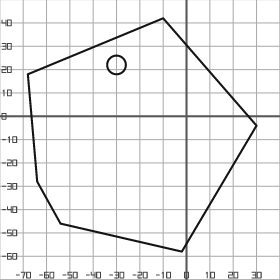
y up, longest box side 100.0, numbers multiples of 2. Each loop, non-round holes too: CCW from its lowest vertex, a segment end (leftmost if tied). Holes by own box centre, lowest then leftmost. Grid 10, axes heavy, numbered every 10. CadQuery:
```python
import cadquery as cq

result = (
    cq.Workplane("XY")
    .moveTo(-2.0, -58.0)
    .lineTo(30.0, -4.0)
    .lineTo(-10.0, 42.0)
    .lineTo(-68.0, 18.0)
    .lineTo(-64.0, -28.0)
    .lineTo(-54.0, -46.0)
    .close()
    .moveTo(-30.0, 22.0)
    .circle(4.0)
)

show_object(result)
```